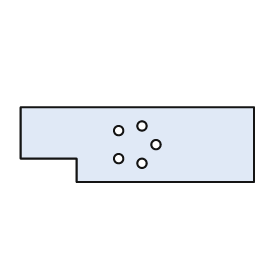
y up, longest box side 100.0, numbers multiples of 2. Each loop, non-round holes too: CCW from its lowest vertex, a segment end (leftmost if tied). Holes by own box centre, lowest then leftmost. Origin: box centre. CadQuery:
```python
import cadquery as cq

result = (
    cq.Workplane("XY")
    .moveTo(-26.0, -16.0)
    .lineTo(50.0, -16.0)
    .lineTo(50.0, 16.0)
    .lineTo(-50.0, 16.0)
    .lineTo(-50.0, -6.0)
    .lineTo(-26.0, -6.0)
    .close()
    .moveTo(2.0, -8.0)
    .circle(2.0)
    .moveTo(-8.0, -6.0)
    .circle(2.0)
    .moveTo(8.0, 0.0)
    .circle(2.0)
    .moveTo(-8.0, 6.0)
    .circle(2.0)
    .moveTo(2.0, 8.0)
    .circle(2.0)
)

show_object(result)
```